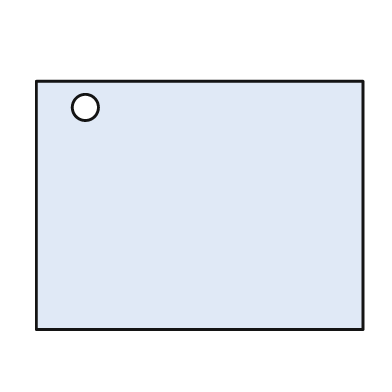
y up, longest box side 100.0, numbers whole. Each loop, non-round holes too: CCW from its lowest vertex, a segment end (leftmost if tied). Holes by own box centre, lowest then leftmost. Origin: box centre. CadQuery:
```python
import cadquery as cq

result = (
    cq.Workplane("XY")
    .moveTo(-50.0, -38.0)
    .lineTo(50.0, -38.0)
    .lineTo(50.0, 38.0)
    .lineTo(-50.0, 38.0)
    .close()
    .moveTo(-35.0, 30.0)
    .circle(4.0)
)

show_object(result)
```